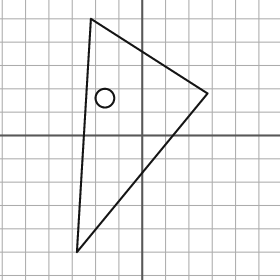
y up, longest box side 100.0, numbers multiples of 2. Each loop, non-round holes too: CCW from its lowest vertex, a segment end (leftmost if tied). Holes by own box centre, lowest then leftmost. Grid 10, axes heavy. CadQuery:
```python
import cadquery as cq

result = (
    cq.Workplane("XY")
    .moveTo(-28.0, -50.0)
    .lineTo(28.0, 18.0)
    .lineTo(-22.0, 50.0)
    .close()
    .moveTo(-16.0, 16.0)
    .circle(4.0)
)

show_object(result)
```